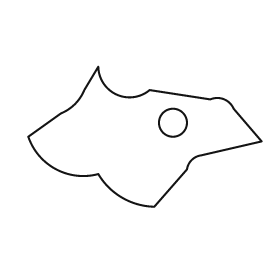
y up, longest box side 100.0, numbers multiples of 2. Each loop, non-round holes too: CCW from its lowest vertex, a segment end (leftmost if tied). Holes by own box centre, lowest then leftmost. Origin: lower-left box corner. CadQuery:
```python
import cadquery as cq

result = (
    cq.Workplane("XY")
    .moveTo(54.0, 0.0)
    .lineTo(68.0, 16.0)
    .threePointArc((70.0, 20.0), (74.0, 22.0))
    .lineTo(100.0, 28.0)
    .lineTo(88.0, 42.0)
    .threePointArc((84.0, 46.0), (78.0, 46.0))
    .lineTo(52.0, 50.0)
    .threePointArc((38.0, 48.0), (30.0, 60.0))
    .lineTo(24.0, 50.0)
    .threePointArc((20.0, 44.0), (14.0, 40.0))
    .lineTo(0.0, 30.0)
    .threePointArc((12.0, 16.0), (30.0, 14.0))
    .threePointArc((40.0, 4.0), (54.0, 0.0))
    .close()
    .moveTo(62.0, 36.0)
    .circle(6.0)
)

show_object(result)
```